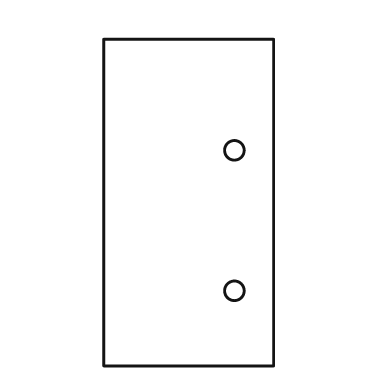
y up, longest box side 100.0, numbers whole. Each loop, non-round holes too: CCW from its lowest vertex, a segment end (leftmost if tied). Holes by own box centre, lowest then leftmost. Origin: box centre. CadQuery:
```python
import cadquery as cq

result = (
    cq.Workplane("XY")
    .moveTo(-26.0, -50.0)
    .lineTo(26.0, -50.0)
    .lineTo(26.0, 50.0)
    .lineTo(-26.0, 50.0)
    .close()
    .moveTo(14.0, -27.0)
    .circle(3.0)
    .moveTo(14.0, 16.0)
    .circle(3.0)
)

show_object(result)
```